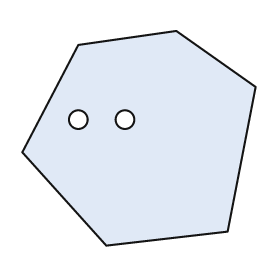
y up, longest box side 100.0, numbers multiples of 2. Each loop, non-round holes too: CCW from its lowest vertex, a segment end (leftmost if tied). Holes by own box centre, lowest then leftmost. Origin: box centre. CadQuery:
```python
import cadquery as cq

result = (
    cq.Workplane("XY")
    .moveTo(-14.0, -46.0)
    .lineTo(38.0, -40.0)
    .lineTo(50.0, 22.0)
    .lineTo(16.0, 46.0)
    .lineTo(-26.0, 40.0)
    .lineTo(-50.0, -6.0)
    .close()
    .moveTo(-26.0, 8.0)
    .circle(4.0)
    .moveTo(-6.0, 8.0)
    .circle(4.0)
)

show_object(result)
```